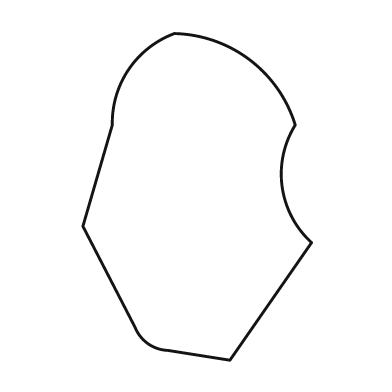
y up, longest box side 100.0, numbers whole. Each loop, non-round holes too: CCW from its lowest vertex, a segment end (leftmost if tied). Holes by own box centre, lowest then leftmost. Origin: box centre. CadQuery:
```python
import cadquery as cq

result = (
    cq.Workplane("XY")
    .moveTo(10.0, -50.0)
    .lineTo(35.0, -14.0)
    .threePointArc((26.0, 3.0), (30.0, 22.0))
    .threePointArc((16.0, 42.0), (-7.0, 50.0))
    .threePointArc((-21.0, 39.0), (-26.0, 22.0))
    .lineTo(-35.0, -9.0)
    .lineTo(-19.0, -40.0)
    .threePointArc((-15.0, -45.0), (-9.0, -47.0))
    .close()
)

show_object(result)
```